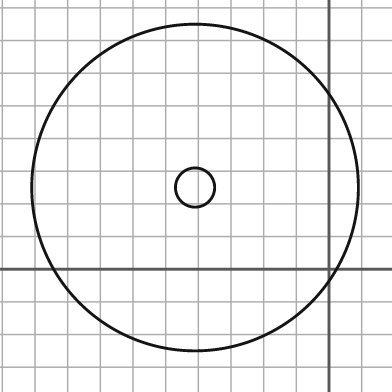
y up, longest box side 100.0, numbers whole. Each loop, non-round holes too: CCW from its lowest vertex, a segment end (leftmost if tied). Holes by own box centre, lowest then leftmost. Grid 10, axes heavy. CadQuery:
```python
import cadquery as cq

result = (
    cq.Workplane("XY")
    .moveTo(-41.0, 25.0)
    .circle(50.0)
    .moveTo(-41.0, 25.0)
    .circle(6.0)
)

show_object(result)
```